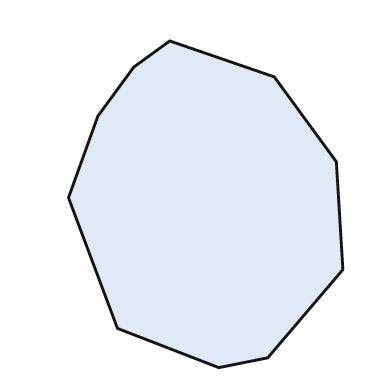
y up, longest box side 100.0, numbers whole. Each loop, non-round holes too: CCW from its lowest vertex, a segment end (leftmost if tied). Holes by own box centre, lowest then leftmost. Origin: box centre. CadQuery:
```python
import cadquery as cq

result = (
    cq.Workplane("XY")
    .moveTo(4.0, -50.0)
    .lineTo(19.0, -47.0)
    .lineTo(42.0, -20.0)
    .lineTo(40.0, 13.0)
    .lineTo(21.0, 39.0)
    .lineTo(-11.0, 50.0)
    .lineTo(-22.0, 42.0)
    .lineTo(-33.0, 27.0)
    .lineTo(-42.0, 2.0)
    .lineTo(-27.0, -38.0)
    .close()
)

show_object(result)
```